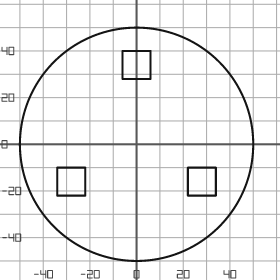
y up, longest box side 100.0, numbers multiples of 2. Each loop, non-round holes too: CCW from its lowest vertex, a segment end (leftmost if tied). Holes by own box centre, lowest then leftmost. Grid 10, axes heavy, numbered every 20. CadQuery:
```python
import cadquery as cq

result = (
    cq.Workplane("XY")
    .moveTo(0.0, 0.0)
    .circle(50.0)
    .moveTo(-34.0, -22.0)
    .lineTo(-22.0, -22.0)
    .lineTo(-22.0, -10.0)
    .lineTo(-34.0, -10.0)
    .close()
    .moveTo(22.0, -22.0)
    .lineTo(34.0, -22.0)
    .lineTo(34.0, -10.0)
    .lineTo(22.0, -10.0)
    .close()
    .moveTo(-6.0, 28.0)
    .lineTo(6.0, 28.0)
    .lineTo(6.0, 40.0)
    .lineTo(-6.0, 40.0)
    .close()
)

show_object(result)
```